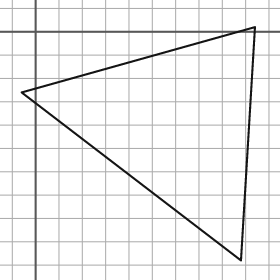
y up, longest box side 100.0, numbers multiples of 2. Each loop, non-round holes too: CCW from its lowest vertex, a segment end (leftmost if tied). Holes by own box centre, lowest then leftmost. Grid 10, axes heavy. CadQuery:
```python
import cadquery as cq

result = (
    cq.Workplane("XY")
    .moveTo(88.0, -98.0)
    .lineTo(94.0, 2.0)
    .lineTo(-6.0, -26.0)
    .close()
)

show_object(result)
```